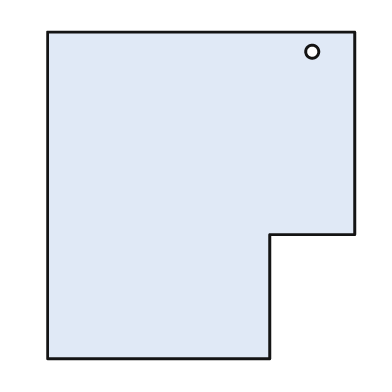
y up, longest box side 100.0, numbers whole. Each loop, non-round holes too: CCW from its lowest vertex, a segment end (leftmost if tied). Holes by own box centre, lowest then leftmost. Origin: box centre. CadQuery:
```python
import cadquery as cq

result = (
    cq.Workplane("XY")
    .moveTo(-47.0, -50.0)
    .lineTo(21.0, -50.0)
    .lineTo(21.0, -12.0)
    .lineTo(47.0, -12.0)
    .lineTo(47.0, 50.0)
    .lineTo(-47.0, 50.0)
    .close()
    .moveTo(34.0, 44.0)
    .circle(2.0)
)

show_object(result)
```